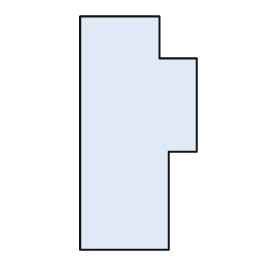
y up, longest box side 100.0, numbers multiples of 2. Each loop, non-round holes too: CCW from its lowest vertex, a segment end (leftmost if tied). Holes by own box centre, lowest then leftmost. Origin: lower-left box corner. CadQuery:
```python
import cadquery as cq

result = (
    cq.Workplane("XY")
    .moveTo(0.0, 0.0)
    .lineTo(38.0, 0.0)
    .lineTo(38.0, 42.0)
    .lineTo(50.0, 42.0)
    .lineTo(50.0, 82.0)
    .lineTo(34.0, 82.0)
    .lineTo(34.0, 100.0)
    .lineTo(0.0, 100.0)
    .close()
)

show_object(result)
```